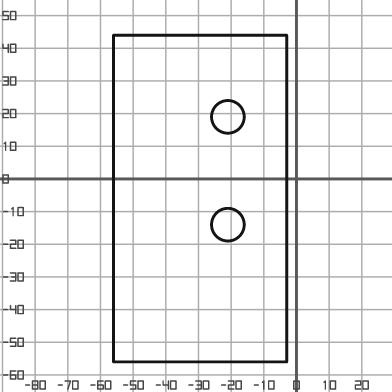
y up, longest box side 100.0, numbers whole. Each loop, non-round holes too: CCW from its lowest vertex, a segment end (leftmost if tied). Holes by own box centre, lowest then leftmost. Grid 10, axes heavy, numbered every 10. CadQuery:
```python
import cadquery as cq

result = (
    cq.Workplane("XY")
    .moveTo(-56.0, -56.0)
    .lineTo(-3.0, -56.0)
    .lineTo(-3.0, 44.0)
    .lineTo(-56.0, 44.0)
    .close()
    .moveTo(-21.0, -14.0)
    .circle(5.0)
    .moveTo(-21.0, 19.0)
    .circle(5.0)
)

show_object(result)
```